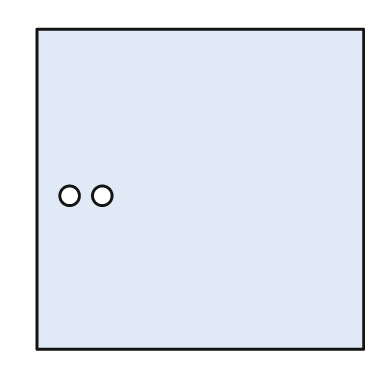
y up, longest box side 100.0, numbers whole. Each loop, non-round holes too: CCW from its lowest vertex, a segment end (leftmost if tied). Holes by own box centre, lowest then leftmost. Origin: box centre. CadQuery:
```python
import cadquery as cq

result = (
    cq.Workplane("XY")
    .moveTo(-50.0, -49.0)
    .lineTo(50.0, -49.0)
    .lineTo(50.0, 49.0)
    .lineTo(-50.0, 49.0)
    .close()
    .moveTo(-40.0, -2.0)
    .circle(3.0)
    .moveTo(-30.0, -2.0)
    .circle(3.0)
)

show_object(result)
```